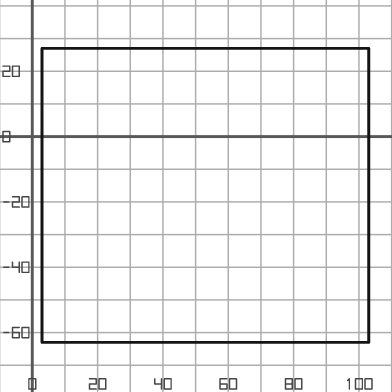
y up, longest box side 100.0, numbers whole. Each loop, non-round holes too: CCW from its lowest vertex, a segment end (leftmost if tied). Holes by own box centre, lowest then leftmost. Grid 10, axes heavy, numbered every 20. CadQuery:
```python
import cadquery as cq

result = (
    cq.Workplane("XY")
    .moveTo(3.0, -63.0)
    .lineTo(103.0, -63.0)
    .lineTo(103.0, 27.0)
    .lineTo(3.0, 27.0)
    .close()
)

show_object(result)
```